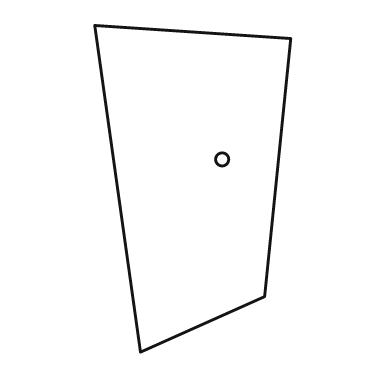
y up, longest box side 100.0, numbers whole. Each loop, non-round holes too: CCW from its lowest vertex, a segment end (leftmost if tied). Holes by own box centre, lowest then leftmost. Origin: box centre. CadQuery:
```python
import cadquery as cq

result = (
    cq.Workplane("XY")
    .moveTo(-16.0, -50.0)
    .lineTo(22.0, -33.0)
    .lineTo(30.0, 46.0)
    .lineTo(-30.0, 50.0)
    .close()
    .moveTo(9.0, 9.0)
    .circle(2.0)
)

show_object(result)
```